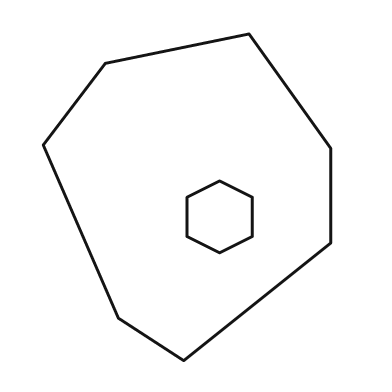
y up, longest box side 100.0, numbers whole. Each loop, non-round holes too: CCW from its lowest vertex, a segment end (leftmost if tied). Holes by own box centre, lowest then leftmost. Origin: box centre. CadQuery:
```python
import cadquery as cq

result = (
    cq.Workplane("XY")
    .moveTo(-1.0, -50.0)
    .lineTo(44.0, -14.0)
    .lineTo(44.0, 15.0)
    .lineTo(19.0, 50.0)
    .lineTo(-25.0, 41.0)
    .lineTo(-44.0, 16.0)
    .lineTo(-21.0, -37.0)
    .close()
    .moveTo(10.0, -17.0)
    .lineTo(20.0, -12.0)
    .lineTo(20.0, 0.0)
    .lineTo(10.0, 5.0)
    .lineTo(0.0, 0.0)
    .lineTo(0.0, -12.0)
    .close()
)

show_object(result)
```